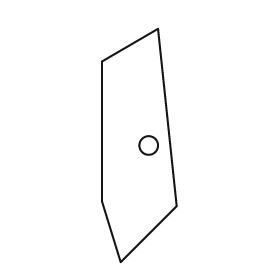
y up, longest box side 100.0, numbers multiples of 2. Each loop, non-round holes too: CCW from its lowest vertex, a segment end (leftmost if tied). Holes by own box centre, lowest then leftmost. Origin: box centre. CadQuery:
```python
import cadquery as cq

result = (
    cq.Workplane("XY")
    .moveTo(-8.0, -50.0)
    .lineTo(16.0, -26.0)
    .lineTo(8.0, 50.0)
    .lineTo(-16.0, 36.0)
    .lineTo(-16.0, -24.0)
    .close()
    .moveTo(4.0, 0.0)
    .circle(4.0)
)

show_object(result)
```